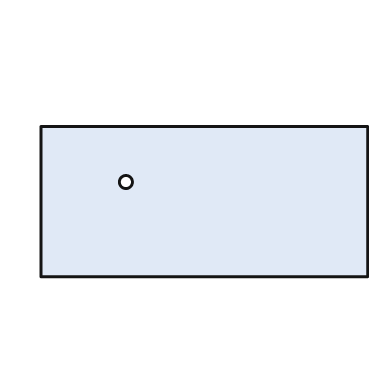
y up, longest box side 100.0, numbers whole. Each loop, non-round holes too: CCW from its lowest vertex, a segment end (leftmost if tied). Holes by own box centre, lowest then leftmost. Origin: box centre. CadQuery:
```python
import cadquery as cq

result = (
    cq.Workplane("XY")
    .moveTo(-50.0, -23.0)
    .lineTo(50.0, -23.0)
    .lineTo(50.0, 23.0)
    .lineTo(-50.0, 23.0)
    .close()
    .moveTo(-24.0, 6.0)
    .circle(2.0)
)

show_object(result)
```